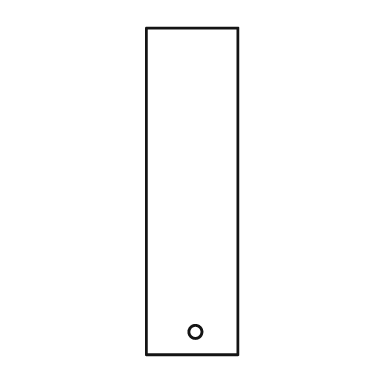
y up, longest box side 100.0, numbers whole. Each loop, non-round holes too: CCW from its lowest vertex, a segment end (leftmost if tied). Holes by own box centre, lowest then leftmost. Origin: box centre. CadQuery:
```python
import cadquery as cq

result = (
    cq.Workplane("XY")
    .moveTo(-14.0, -50.0)
    .lineTo(14.0, -50.0)
    .lineTo(14.0, 50.0)
    .lineTo(-14.0, 50.0)
    .close()
    .moveTo(1.0, -43.0)
    .circle(2.0)
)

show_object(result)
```